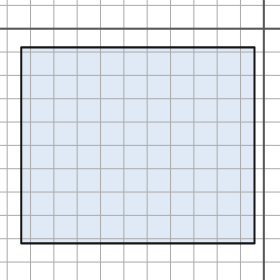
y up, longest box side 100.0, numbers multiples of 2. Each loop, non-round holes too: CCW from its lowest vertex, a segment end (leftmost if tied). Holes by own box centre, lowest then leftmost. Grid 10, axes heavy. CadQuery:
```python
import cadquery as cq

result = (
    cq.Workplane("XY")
    .moveTo(-104.0, -92.0)
    .lineTo(-4.0, -92.0)
    .lineTo(-4.0, -8.0)
    .lineTo(-104.0, -8.0)
    .close()
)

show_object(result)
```